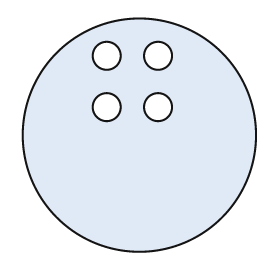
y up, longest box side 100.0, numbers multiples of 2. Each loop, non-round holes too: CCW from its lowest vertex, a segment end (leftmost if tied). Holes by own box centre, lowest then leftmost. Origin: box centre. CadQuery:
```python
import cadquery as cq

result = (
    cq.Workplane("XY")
    .moveTo(0.0, 0.0)
    .circle(50.0)
    .moveTo(-14.0, 12.0)
    .circle(6.0)
    .moveTo(8.0, 12.0)
    .circle(6.0)
    .moveTo(-14.0, 34.0)
    .circle(6.0)
    .moveTo(8.0, 34.0)
    .circle(6.0)
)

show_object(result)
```